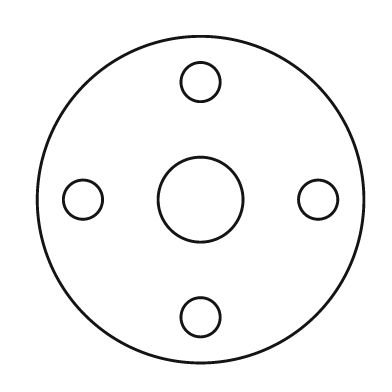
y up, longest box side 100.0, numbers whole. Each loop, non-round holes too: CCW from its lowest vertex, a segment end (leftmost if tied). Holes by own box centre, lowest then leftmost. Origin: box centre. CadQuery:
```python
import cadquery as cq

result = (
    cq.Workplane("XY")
    .moveTo(0.0, 0.0)
    .circle(50.0)
    .moveTo(0.0, -36.0)
    .circle(6.0)
    .moveTo(-36.0, 0.0)
    .circle(6.0)
    .moveTo(0.0, 0.0)
    .circle(13.0)
    .moveTo(36.0, 0.0)
    .circle(6.0)
    .moveTo(0.0, 36.0)
    .circle(6.0)
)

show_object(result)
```